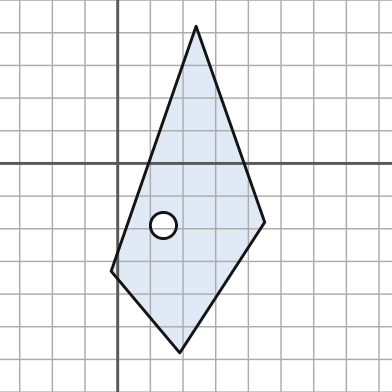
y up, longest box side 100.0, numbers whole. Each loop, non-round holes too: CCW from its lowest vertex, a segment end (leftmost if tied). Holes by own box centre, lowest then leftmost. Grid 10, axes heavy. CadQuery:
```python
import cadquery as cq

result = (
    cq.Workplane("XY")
    .moveTo(19.0, -58.0)
    .lineTo(45.0, -18.0)
    .lineTo(24.0, 42.0)
    .lineTo(-2.0, -33.0)
    .close()
    .moveTo(14.0, -19.0)
    .circle(4.0)
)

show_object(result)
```